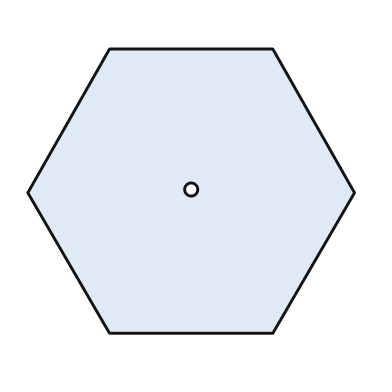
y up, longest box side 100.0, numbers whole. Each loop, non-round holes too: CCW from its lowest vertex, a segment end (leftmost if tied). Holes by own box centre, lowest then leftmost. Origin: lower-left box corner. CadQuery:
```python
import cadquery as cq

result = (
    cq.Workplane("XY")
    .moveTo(25.0, 0.0)
    .lineTo(75.0, 0.0)
    .lineTo(100.0, 43.0)
    .lineTo(75.0, 87.0)
    .lineTo(25.0, 87.0)
    .lineTo(0.0, 43.0)
    .close()
    .moveTo(50.0, 44.0)
    .circle(2.0)
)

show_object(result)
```